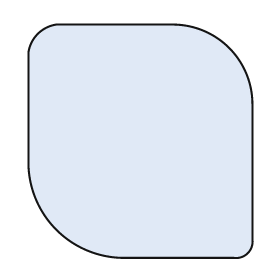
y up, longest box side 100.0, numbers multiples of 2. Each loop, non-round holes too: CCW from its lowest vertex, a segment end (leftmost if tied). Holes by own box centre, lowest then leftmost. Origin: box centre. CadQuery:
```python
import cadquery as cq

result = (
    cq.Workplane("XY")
    .moveTo(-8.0, -50.0)
    .lineTo(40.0, -50.0)
    .threePointArc((46.0, -48.0), (48.0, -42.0))
    .lineTo(48.0, 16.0)
    .threePointArc((38.0, 40.0), (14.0, 50.0))
    .lineTo(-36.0, 50.0)
    .threePointArc((-44.0, 46.0), (-48.0, 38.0))
    .lineTo(-48.0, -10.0)
    .threePointArc((-36.0, -38.0), (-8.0, -50.0))
    .close()
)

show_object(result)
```